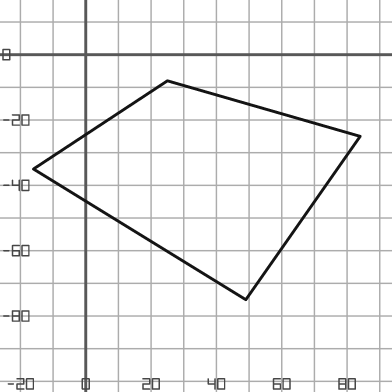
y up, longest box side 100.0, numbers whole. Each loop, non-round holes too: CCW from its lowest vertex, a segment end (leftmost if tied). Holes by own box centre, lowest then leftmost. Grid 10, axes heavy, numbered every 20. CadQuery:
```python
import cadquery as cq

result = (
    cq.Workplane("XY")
    .moveTo(49.0, -75.0)
    .lineTo(84.0, -25.0)
    .lineTo(25.0, -8.0)
    .lineTo(-16.0, -35.0)
    .close()
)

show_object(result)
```